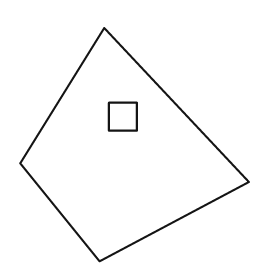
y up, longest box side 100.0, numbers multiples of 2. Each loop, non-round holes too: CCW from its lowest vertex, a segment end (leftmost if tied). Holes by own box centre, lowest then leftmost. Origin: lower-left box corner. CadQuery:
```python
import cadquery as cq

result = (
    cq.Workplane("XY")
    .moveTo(34.0, 0.0)
    .lineTo(98.0, 34.0)
    .lineTo(36.0, 100.0)
    .lineTo(0.0, 42.0)
    .close()
    .moveTo(38.0, 56.0)
    .lineTo(50.0, 56.0)
    .lineTo(50.0, 68.0)
    .lineTo(38.0, 68.0)
    .close()
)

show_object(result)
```